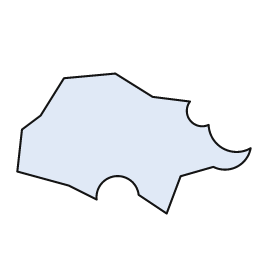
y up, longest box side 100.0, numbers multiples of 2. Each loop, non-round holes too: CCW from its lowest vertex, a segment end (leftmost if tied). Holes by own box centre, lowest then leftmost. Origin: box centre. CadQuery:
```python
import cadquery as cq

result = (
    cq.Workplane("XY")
    .moveTo(14.0, -30.0)
    .lineTo(20.0, -14.0)
    .lineTo(34.0, -10.0)
    .threePointArc((44.0, -10.0), (50.0, -2.0))
    .threePointArc((38.0, -2.0), (32.0, 8.0))
    .threePointArc((24.0, 10.0), (24.0, 18.0))
    .lineTo(8.0, 20.0)
    .lineTo(-8.0, 30.0)
    .lineTo(-30.0, 28.0)
    .lineTo(-40.0, 12.0)
    .lineTo(-48.0, 6.0)
    .lineTo(-50.0, -12.0)
    .lineTo(-28.0, -18.0)
    .lineTo(-16.0, -24.0)
    .threePointArc((-8.0, -14.0), (2.0, -22.0))
    .close()
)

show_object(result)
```